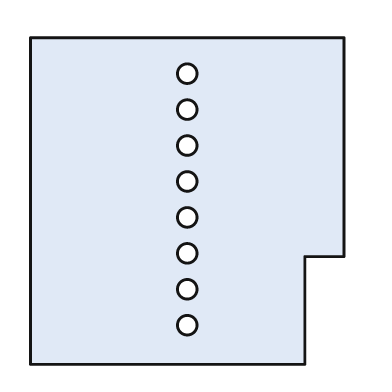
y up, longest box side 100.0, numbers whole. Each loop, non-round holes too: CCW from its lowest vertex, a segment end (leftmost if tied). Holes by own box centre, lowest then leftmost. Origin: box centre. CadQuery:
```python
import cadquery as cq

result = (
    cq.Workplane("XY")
    .moveTo(-48.0, -50.0)
    .lineTo(36.0, -50.0)
    .lineTo(36.0, -17.0)
    .lineTo(48.0, -17.0)
    .lineTo(48.0, 50.0)
    .lineTo(-48.0, 50.0)
    .close()
    .moveTo(0.0, -38.0)
    .circle(3.0)
    .moveTo(0.0, -27.0)
    .circle(3.0)
    .moveTo(0.0, -16.0)
    .circle(3.0)
    .moveTo(0.0, -5.0)
    .circle(3.0)
    .moveTo(0.0, 6.0)
    .circle(3.0)
    .moveTo(0.0, 17.0)
    .circle(3.0)
    .moveTo(0.0, 28.0)
    .circle(3.0)
    .moveTo(0.0, 39.0)
    .circle(3.0)
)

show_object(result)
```